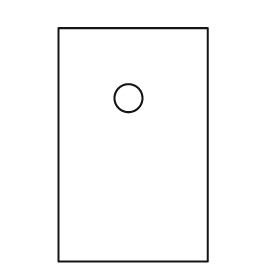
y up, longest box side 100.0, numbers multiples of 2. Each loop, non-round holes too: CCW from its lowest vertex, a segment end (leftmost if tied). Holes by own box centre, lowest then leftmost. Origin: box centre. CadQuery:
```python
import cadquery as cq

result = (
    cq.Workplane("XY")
    .moveTo(-32.0, -50.0)
    .lineTo(32.0, -50.0)
    .lineTo(32.0, 50.0)
    .lineTo(-32.0, 50.0)
    .close()
    .moveTo(-2.0, 20.0)
    .circle(6.0)
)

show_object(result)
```